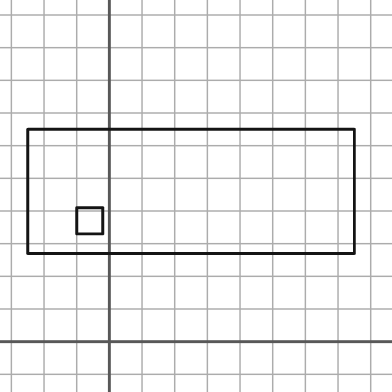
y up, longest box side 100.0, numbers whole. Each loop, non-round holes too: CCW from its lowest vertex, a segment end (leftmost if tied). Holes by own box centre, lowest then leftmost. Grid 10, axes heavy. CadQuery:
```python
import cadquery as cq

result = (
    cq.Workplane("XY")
    .moveTo(-25.0, 27.0)
    .lineTo(75.0, 27.0)
    .lineTo(75.0, 65.0)
    .lineTo(-25.0, 65.0)
    .close()
    .moveTo(-10.0, 33.0)
    .lineTo(-2.0, 33.0)
    .lineTo(-2.0, 41.0)
    .lineTo(-10.0, 41.0)
    .close()
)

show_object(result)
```